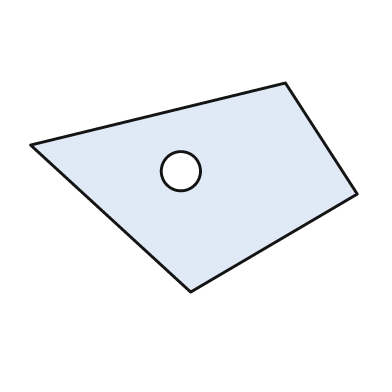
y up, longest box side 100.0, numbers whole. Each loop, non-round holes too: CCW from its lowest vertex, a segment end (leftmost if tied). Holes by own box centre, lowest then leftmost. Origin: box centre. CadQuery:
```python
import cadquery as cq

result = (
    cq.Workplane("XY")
    .moveTo(-1.0, -32.0)
    .lineTo(50.0, -2.0)
    .lineTo(28.0, 32.0)
    .lineTo(-50.0, 13.0)
    .close()
    .moveTo(-4.0, 5.0)
    .circle(6.0)
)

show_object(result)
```